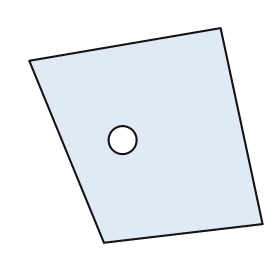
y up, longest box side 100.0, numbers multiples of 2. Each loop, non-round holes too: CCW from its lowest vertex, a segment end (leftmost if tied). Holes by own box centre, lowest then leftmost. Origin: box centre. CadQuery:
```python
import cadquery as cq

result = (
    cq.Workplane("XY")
    .moveTo(-18.0, -46.0)
    .lineTo(50.0, -38.0)
    .lineTo(32.0, 46.0)
    .lineTo(-50.0, 32.0)
    .close()
    .moveTo(-10.0, -2.0)
    .circle(6.0)
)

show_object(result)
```